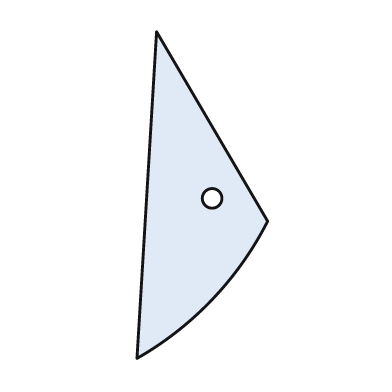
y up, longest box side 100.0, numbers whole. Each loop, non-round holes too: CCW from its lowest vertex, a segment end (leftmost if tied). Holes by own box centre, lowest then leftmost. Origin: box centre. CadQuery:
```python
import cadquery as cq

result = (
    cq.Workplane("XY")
    .moveTo(-20.0, -50.0)
    .threePointArc((3.0, -32.0), (20.0, -8.0))
    .lineTo(-14.0, 50.0)
    .close()
    .moveTo(3.0, -1.0)
    .circle(3.0)
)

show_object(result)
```